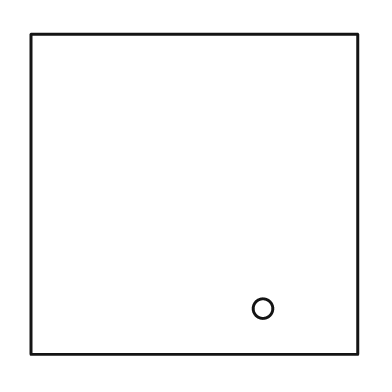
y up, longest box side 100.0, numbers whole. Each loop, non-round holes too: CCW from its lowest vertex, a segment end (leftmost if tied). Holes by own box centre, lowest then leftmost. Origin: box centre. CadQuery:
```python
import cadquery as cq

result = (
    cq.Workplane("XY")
    .moveTo(-50.0, -49.0)
    .lineTo(50.0, -49.0)
    .lineTo(50.0, 49.0)
    .lineTo(-50.0, 49.0)
    .close()
    .moveTo(21.0, -35.0)
    .circle(3.0)
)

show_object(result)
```